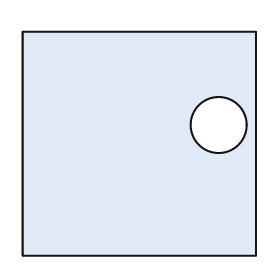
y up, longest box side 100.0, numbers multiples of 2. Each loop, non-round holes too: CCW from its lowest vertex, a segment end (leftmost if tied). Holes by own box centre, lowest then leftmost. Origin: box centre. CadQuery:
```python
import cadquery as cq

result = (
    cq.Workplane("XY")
    .moveTo(-50.0, -48.0)
    .lineTo(50.0, -48.0)
    .lineTo(50.0, 48.0)
    .lineTo(-50.0, 48.0)
    .close()
    .moveTo(34.0, 8.0)
    .circle(12.0)
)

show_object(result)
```